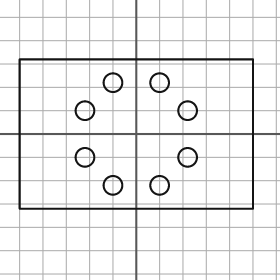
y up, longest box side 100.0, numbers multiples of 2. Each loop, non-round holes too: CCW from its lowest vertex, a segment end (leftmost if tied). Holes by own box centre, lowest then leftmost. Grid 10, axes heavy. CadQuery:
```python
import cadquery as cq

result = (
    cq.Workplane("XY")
    .moveTo(-50.0, -32.0)
    .lineTo(50.0, -32.0)
    .lineTo(50.0, 32.0)
    .lineTo(-50.0, 32.0)
    .close()
    .moveTo(-10.0, -22.0)
    .circle(4.0)
    .moveTo(10.0, -22.0)
    .circle(4.0)
    .moveTo(-22.0, -10.0)
    .circle(4.0)
    .moveTo(22.0, -10.0)
    .circle(4.0)
    .moveTo(-22.0, 10.0)
    .circle(4.0)
    .moveTo(22.0, 10.0)
    .circle(4.0)
    .moveTo(-10.0, 22.0)
    .circle(4.0)
    .moveTo(10.0, 22.0)
    .circle(4.0)
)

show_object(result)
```